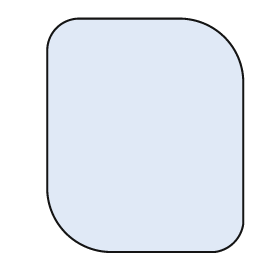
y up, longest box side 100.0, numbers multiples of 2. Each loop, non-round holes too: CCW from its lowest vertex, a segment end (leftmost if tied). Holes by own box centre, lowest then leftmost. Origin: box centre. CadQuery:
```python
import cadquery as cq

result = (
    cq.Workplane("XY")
    .moveTo(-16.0, -50.0)
    .lineTo(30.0, -50.0)
    .threePointArc((38.0, -46.0), (42.0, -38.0))
    .lineTo(42.0, 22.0)
    .threePointArc((34.0, 42.0), (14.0, 50.0))
    .lineTo(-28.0, 50.0)
    .threePointArc((-38.0, 46.0), (-42.0, 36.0))
    .lineTo(-42.0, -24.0)
    .threePointArc((-34.0, -42.0), (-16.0, -50.0))
    .close()
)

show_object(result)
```